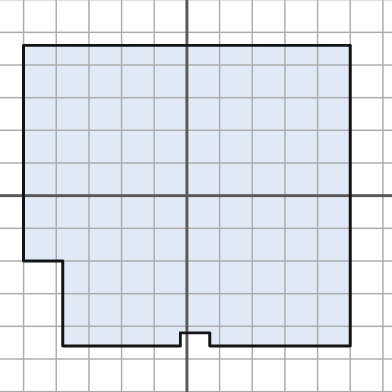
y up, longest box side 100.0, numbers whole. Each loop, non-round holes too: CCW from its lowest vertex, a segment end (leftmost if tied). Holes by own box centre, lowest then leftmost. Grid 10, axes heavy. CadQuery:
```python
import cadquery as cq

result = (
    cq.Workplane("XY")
    .moveTo(-38.0, -46.0)
    .lineTo(-2.0, -46.0)
    .lineTo(-2.0, -42.0)
    .lineTo(7.0, -42.0)
    .lineTo(7.0, -46.0)
    .lineTo(50.0, -46.0)
    .lineTo(50.0, 46.0)
    .lineTo(-50.0, 46.0)
    .lineTo(-50.0, -20.0)
    .lineTo(-38.0, -20.0)
    .close()
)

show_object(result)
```